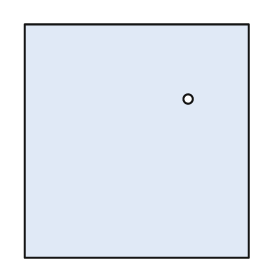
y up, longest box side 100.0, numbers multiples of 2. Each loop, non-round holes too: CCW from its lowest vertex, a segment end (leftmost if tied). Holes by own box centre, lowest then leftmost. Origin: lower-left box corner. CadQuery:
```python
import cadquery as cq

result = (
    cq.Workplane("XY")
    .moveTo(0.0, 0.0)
    .lineTo(96.0, 0.0)
    .lineTo(96.0, 100.0)
    .lineTo(0.0, 100.0)
    .close()
    .moveTo(70.0, 68.0)
    .circle(2.0)
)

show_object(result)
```